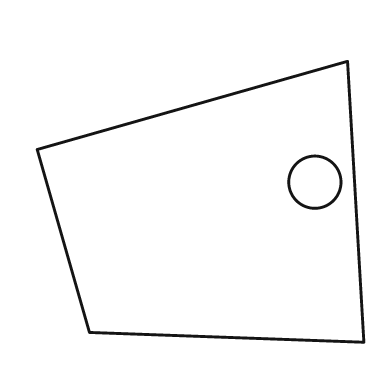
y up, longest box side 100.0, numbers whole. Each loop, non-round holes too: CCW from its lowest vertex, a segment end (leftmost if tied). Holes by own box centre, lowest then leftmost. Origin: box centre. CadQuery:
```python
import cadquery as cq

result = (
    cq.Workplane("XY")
    .moveTo(50.0, -43.0)
    .lineTo(45.0, 43.0)
    .lineTo(-50.0, 16.0)
    .lineTo(-34.0, -40.0)
    .close()
    .moveTo(35.0, 6.0)
    .circle(8.0)
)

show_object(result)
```